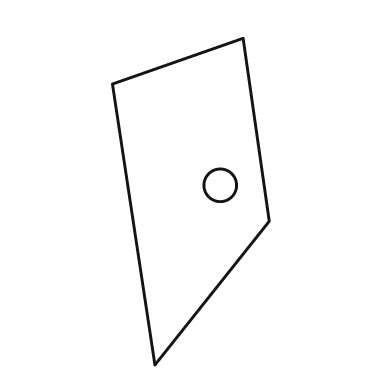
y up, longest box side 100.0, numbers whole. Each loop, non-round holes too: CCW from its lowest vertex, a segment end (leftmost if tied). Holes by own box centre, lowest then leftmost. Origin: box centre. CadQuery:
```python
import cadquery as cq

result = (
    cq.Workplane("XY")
    .moveTo(-11.0, -50.0)
    .lineTo(24.0, -6.0)
    .lineTo(16.0, 50.0)
    .lineTo(-24.0, 36.0)
    .close()
    .moveTo(9.0, 5.0)
    .circle(5.0)
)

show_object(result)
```